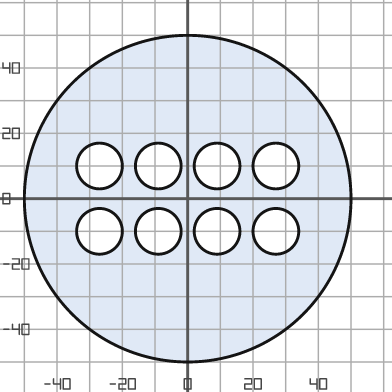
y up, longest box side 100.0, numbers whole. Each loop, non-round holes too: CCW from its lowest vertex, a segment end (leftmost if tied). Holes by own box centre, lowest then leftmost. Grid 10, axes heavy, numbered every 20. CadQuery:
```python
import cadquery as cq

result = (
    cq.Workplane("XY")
    .moveTo(0.0, 0.0)
    .circle(50.0)
    .moveTo(-27.0, -10.0)
    .circle(7.0)
    .moveTo(-9.0, -10.0)
    .circle(7.0)
    .moveTo(9.0, -10.0)
    .circle(7.0)
    .moveTo(27.0, -10.0)
    .circle(7.0)
    .moveTo(-27.0, 10.0)
    .circle(7.0)
    .moveTo(-9.0, 10.0)
    .circle(7.0)
    .moveTo(9.0, 10.0)
    .circle(7.0)
    .moveTo(27.0, 10.0)
    .circle(7.0)
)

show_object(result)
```